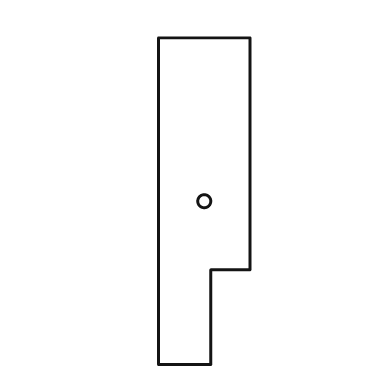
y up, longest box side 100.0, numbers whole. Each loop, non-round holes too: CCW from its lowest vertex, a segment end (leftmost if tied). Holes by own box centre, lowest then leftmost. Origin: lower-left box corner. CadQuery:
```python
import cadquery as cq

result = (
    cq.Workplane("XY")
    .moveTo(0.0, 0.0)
    .lineTo(16.0, 0.0)
    .lineTo(16.0, 29.0)
    .lineTo(28.0, 29.0)
    .lineTo(28.0, 100.0)
    .lineTo(0.0, 100.0)
    .close()
    .moveTo(14.0, 50.0)
    .circle(2.0)
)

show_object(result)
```